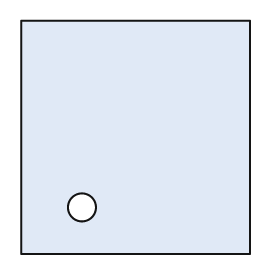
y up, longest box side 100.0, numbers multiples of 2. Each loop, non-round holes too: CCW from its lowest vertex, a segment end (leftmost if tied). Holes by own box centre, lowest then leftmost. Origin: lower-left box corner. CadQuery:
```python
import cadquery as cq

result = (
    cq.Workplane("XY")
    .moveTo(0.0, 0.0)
    .lineTo(98.0, 0.0)
    .lineTo(98.0, 100.0)
    .lineTo(0.0, 100.0)
    .close()
    .moveTo(26.0, 20.0)
    .circle(6.0)
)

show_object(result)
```